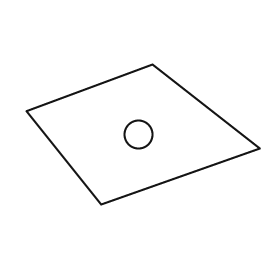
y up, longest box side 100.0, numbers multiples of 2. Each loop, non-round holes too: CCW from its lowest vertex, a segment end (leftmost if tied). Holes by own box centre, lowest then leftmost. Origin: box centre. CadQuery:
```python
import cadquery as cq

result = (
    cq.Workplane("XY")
    .moveTo(-18.0, -30.0)
    .lineTo(50.0, -6.0)
    .lineTo(4.0, 30.0)
    .lineTo(-50.0, 10.0)
    .close()
    .moveTo(-2.0, 0.0)
    .circle(6.0)
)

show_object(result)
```